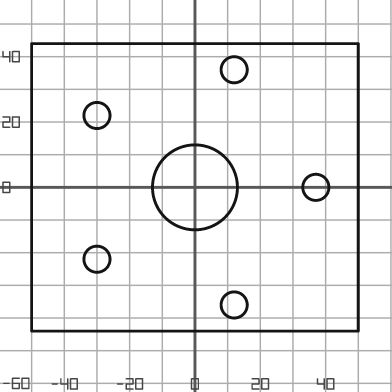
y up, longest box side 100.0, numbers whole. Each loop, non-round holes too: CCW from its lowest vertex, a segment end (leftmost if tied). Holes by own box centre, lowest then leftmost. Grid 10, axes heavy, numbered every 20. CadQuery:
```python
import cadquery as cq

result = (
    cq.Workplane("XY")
    .moveTo(-50.0, -44.0)
    .lineTo(50.0, -44.0)
    .lineTo(50.0, 44.0)
    .lineTo(-50.0, 44.0)
    .close()
    .moveTo(12.0, -36.0)
    .circle(4.0)
    .moveTo(-30.0, -22.0)
    .circle(4.0)
    .moveTo(0.0, 0.0)
    .circle(13.0)
    .moveTo(37.0, 0.0)
    .circle(4.0)
    .moveTo(-30.0, 22.0)
    .circle(4.0)
    .moveTo(12.0, 36.0)
    .circle(4.0)
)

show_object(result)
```